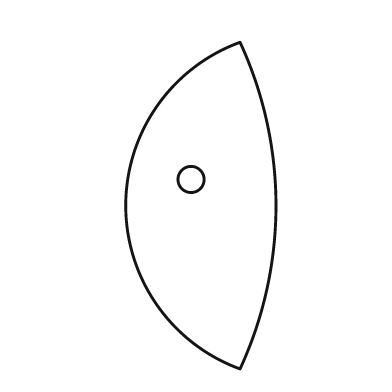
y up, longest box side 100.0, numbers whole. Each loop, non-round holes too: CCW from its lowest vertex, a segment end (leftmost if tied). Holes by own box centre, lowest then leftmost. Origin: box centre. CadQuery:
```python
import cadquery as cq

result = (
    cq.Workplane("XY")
    .moveTo(12.0, -50.0)
    .threePointArc((23.0, 0.0), (12.0, 50.0))
    .threePointArc((-23.0, 0.0), (12.0, -50.0))
    .close()
    .moveTo(-3.0, 8.0)
    .circle(4.0)
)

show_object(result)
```